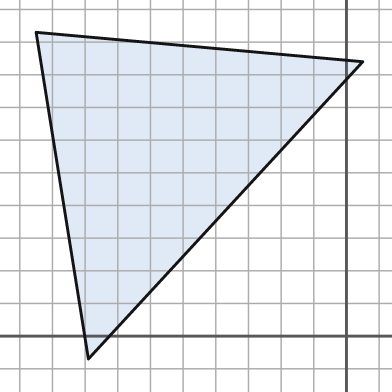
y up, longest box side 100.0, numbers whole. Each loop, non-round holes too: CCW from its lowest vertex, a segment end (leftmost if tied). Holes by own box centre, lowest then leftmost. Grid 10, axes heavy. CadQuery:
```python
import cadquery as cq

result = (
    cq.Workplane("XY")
    .moveTo(-79.0, -7.0)
    .lineTo(5.0, 84.0)
    .lineTo(-95.0, 93.0)
    .close()
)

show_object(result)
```